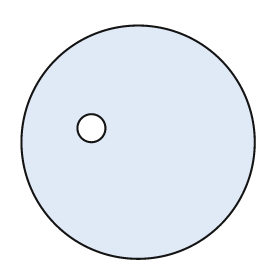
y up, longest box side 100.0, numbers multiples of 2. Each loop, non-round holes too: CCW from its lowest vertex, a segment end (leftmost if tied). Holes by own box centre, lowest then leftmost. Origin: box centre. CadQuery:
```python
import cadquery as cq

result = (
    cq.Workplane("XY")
    .moveTo(0.0, 0.0)
    .circle(50.0)
    .moveTo(-20.0, 6.0)
    .circle(6.0)
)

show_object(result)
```